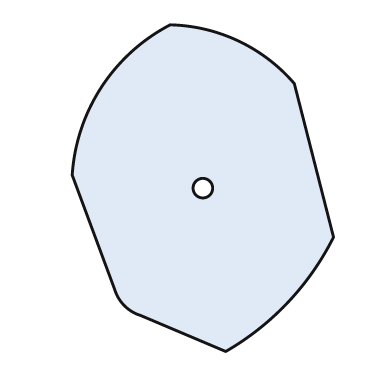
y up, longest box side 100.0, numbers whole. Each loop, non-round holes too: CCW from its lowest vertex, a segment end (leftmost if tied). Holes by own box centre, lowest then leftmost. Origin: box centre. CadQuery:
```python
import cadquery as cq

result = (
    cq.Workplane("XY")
    .moveTo(7.0, -50.0)
    .threePointArc((26.0, -35.0), (40.0, -15.0))
    .lineTo(28.0, 32.0)
    .threePointArc((11.0, 45.0), (-10.0, 50.0))
    .threePointArc((-31.0, 31.0), (-40.0, 4.0))
    .lineTo(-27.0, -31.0)
    .threePointArc((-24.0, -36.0), (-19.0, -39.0))
    .close()
    .moveTo(0.0, 0.0)
    .circle(3.0)
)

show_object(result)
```